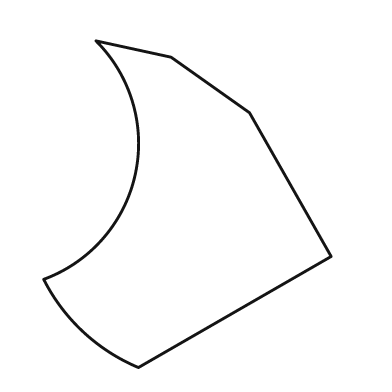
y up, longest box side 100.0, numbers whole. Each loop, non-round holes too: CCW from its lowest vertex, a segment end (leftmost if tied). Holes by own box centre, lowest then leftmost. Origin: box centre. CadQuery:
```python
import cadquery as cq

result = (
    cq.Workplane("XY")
    .moveTo(-15.0, -50.0)
    .lineTo(44.0, -16.0)
    .lineTo(19.0, 28.0)
    .lineTo(-5.0, 45.0)
    .lineTo(-28.0, 50.0)
    .threePointArc((-16.0, 9.0), (-44.0, -23.0))
    .threePointArc((-32.0, -39.0), (-15.0, -50.0))
    .close()
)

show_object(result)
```